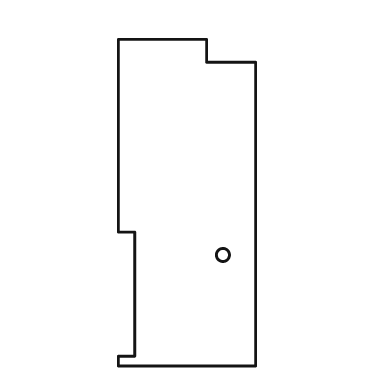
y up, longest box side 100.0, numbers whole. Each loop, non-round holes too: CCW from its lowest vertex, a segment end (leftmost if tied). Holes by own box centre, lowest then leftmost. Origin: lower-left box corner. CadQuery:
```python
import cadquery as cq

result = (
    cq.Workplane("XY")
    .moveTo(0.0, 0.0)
    .lineTo(42.0, 0.0)
    .lineTo(42.0, 93.0)
    .lineTo(27.0, 93.0)
    .lineTo(27.0, 100.0)
    .lineTo(0.0, 100.0)
    .lineTo(0.0, 41.0)
    .lineTo(5.0, 41.0)
    .lineTo(5.0, 3.0)
    .lineTo(0.0, 3.0)
    .close()
    .moveTo(32.0, 34.0)
    .circle(2.0)
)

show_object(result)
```